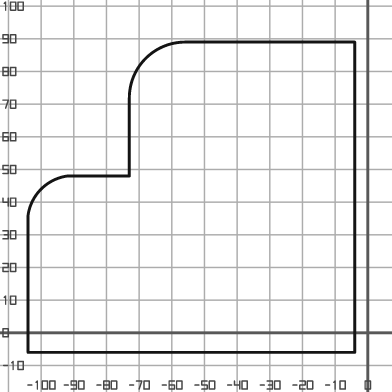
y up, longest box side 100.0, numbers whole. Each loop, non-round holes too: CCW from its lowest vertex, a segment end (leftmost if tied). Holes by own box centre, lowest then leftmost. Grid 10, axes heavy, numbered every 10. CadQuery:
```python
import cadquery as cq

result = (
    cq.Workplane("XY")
    .moveTo(-104.0, -6.0)
    .lineTo(-4.0, -6.0)
    .lineTo(-4.0, 89.0)
    .lineTo(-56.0, 89.0)
    .threePointArc((-68.0, 84.0), (-73.0, 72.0))
    .lineTo(-73.0, 48.0)
    .lineTo(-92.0, 48.0)
    .threePointArc((-100.0, 44.0), (-104.0, 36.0))
    .close()
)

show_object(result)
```